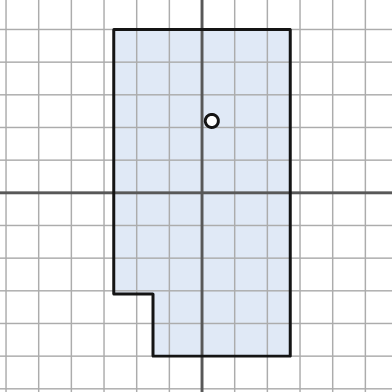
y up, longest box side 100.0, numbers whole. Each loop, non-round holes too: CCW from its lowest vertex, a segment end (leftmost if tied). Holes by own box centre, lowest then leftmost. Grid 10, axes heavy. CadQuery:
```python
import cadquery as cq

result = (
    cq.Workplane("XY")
    .moveTo(-15.0, -50.0)
    .lineTo(27.0, -50.0)
    .lineTo(27.0, 50.0)
    .lineTo(-27.0, 50.0)
    .lineTo(-27.0, -31.0)
    .lineTo(-15.0, -31.0)
    .close()
    .moveTo(3.0, 22.0)
    .circle(2.0)
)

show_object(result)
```